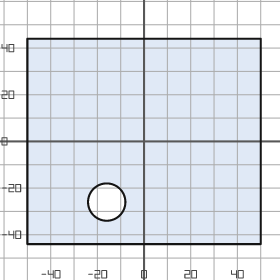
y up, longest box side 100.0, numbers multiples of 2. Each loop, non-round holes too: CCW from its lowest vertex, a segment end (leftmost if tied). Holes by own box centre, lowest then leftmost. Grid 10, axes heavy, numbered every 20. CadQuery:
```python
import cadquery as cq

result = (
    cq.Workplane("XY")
    .moveTo(-50.0, -44.0)
    .lineTo(50.0, -44.0)
    .lineTo(50.0, 44.0)
    .lineTo(-50.0, 44.0)
    .close()
    .moveTo(-16.0, -26.0)
    .circle(8.0)
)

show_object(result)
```